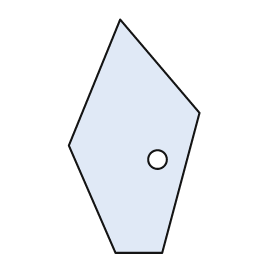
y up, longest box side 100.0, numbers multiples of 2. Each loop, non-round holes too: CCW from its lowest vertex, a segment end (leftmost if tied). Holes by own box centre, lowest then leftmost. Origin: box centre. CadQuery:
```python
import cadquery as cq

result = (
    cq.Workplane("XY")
    .moveTo(-8.0, -50.0)
    .lineTo(12.0, -50.0)
    .lineTo(28.0, 10.0)
    .lineTo(-6.0, 50.0)
    .lineTo(-28.0, -4.0)
    .close()
    .moveTo(10.0, -10.0)
    .circle(4.0)
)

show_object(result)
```